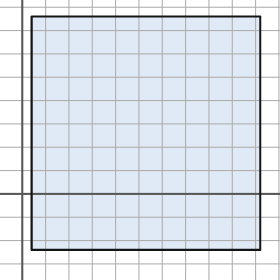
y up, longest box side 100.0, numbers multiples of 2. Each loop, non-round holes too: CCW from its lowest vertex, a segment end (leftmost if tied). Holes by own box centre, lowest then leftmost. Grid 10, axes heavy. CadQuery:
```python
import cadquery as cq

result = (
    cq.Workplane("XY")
    .moveTo(4.0, -24.0)
    .lineTo(102.0, -24.0)
    .lineTo(102.0, 76.0)
    .lineTo(4.0, 76.0)
    .close()
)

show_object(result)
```